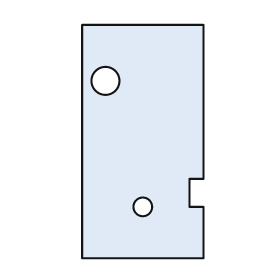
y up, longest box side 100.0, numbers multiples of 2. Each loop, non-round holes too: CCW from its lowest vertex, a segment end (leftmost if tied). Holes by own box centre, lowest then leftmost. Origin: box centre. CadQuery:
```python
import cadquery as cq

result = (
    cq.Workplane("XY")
    .moveTo(-26.0, -50.0)
    .lineTo(26.0, -50.0)
    .lineTo(26.0, -28.0)
    .lineTo(20.0, -28.0)
    .lineTo(20.0, -16.0)
    .lineTo(26.0, -16.0)
    .lineTo(26.0, 50.0)
    .lineTo(-26.0, 50.0)
    .close()
    .moveTo(0.0, -28.0)
    .circle(4.0)
    .moveTo(-16.0, 26.0)
    .circle(6.0)
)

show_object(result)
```